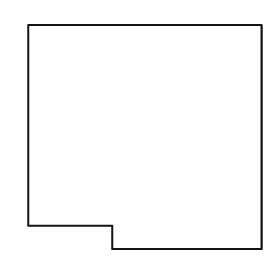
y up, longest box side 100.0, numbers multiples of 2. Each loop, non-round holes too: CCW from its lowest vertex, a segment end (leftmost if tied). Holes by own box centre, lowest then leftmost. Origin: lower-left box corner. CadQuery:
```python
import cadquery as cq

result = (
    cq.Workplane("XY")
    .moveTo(36.0, 0.0)
    .lineTo(100.0, 0.0)
    .lineTo(100.0, 96.0)
    .lineTo(0.0, 96.0)
    .lineTo(0.0, 10.0)
    .lineTo(36.0, 10.0)
    .close()
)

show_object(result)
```